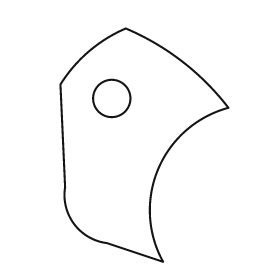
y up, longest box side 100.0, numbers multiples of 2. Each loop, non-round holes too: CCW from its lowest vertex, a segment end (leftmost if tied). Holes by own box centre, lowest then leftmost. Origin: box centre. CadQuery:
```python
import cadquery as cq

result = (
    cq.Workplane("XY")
    .moveTo(8.0, -50.0)
    .threePointArc((6.0, -10.0), (36.0, 16.0))
    .threePointArc((16.0, 36.0), (-8.0, 50.0))
    .threePointArc((-24.0, 40.0), (-36.0, 26.0))
    .lineTo(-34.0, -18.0)
    .threePointArc((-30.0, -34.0), (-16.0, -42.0))
    .close()
    .moveTo(-14.0, 20.0)
    .circle(8.0)
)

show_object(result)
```